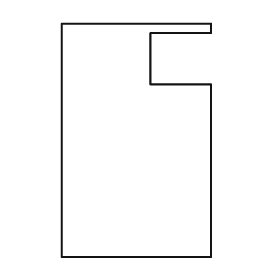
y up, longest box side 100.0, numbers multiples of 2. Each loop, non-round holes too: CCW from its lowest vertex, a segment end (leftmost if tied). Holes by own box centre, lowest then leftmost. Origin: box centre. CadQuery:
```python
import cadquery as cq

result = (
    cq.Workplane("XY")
    .moveTo(-32.0, -50.0)
    .lineTo(32.0, -50.0)
    .lineTo(32.0, 24.0)
    .lineTo(6.0, 24.0)
    .lineTo(6.0, 46.0)
    .lineTo(32.0, 46.0)
    .lineTo(32.0, 50.0)
    .lineTo(-32.0, 50.0)
    .close()
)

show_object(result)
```